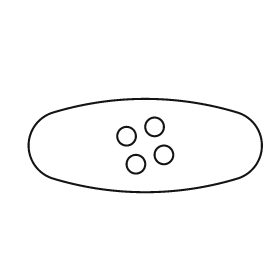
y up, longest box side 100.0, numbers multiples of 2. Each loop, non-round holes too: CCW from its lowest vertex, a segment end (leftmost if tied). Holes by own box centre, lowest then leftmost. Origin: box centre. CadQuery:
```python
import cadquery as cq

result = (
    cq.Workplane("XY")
    .moveTo(-40.0, -14.0)
    .threePointArc((0.0, -20.0), (40.0, -14.0))
    .threePointArc((50.0, 0.0), (40.0, 14.0))
    .threePointArc((0.0, 20.0), (-40.0, 14.0))
    .threePointArc((-50.0, 0.0), (-40.0, -14.0))
    .close()
    .moveTo(-4.0, -8.0)
    .circle(4.0)
    .moveTo(8.0, -4.0)
    .circle(4.0)
    .moveTo(-8.0, 4.0)
    .circle(4.0)
    .moveTo(4.0, 8.0)
    .circle(4.0)
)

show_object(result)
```